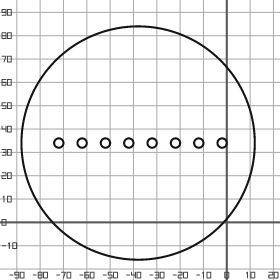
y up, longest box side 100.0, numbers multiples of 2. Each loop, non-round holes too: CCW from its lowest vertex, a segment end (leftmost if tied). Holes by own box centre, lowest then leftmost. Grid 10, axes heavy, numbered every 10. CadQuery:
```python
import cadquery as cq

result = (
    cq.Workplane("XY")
    .moveTo(-38.0, 34.0)
    .circle(50.0)
    .moveTo(-72.0, 34.0)
    .circle(2.0)
    .moveTo(-62.0, 34.0)
    .circle(2.0)
    .moveTo(-52.0, 34.0)
    .circle(2.0)
    .moveTo(-42.0, 34.0)
    .circle(2.0)
    .moveTo(-32.0, 34.0)
    .circle(2.0)
    .moveTo(-22.0, 34.0)
    .circle(2.0)
    .moveTo(-12.0, 34.0)
    .circle(2.0)
    .moveTo(-2.0, 34.0)
    .circle(2.0)
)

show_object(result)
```